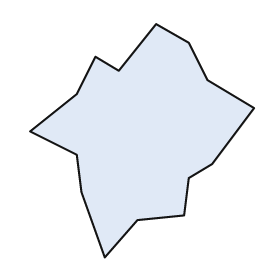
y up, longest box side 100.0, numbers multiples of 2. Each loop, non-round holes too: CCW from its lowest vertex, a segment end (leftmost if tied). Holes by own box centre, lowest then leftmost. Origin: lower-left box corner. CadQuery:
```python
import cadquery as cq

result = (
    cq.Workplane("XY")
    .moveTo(32.0, 0.0)
    .lineTo(46.0, 16.0)
    .lineTo(66.0, 18.0)
    .lineTo(68.0, 34.0)
    .lineTo(78.0, 40.0)
    .lineTo(96.0, 64.0)
    .lineTo(76.0, 76.0)
    .lineTo(68.0, 92.0)
    .lineTo(54.0, 100.0)
    .lineTo(38.0, 80.0)
    .lineTo(28.0, 86.0)
    .lineTo(20.0, 70.0)
    .lineTo(0.0, 54.0)
    .lineTo(20.0, 44.0)
    .lineTo(22.0, 28.0)
    .close()
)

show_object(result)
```